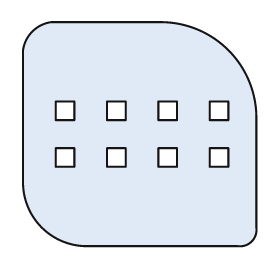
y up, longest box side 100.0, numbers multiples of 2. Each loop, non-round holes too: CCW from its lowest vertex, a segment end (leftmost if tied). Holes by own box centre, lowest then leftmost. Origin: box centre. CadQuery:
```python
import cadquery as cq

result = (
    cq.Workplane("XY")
    .moveTo(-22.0, -48.0)
    .lineTo(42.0, -48.0)
    .threePointArc((48.0, -46.0), (50.0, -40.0))
    .lineTo(50.0, 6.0)
    .threePointArc((38.0, 36.0), (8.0, 48.0))
    .lineTo(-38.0, 48.0)
    .threePointArc((-46.0, 44.0), (-50.0, 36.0))
    .lineTo(-50.0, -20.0)
    .threePointArc((-42.0, -40.0), (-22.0, -48.0))
    .close()
    .moveTo(-36.0, -14.0)
    .lineTo(-28.0, -14.0)
    .lineTo(-28.0, -6.0)
    .lineTo(-36.0, -6.0)
    .close()
    .moveTo(-14.0, -14.0)
    .lineTo(-6.0, -14.0)
    .lineTo(-6.0, -6.0)
    .lineTo(-14.0, -6.0)
    .close()
    .moveTo(8.0, -14.0)
    .lineTo(16.0, -14.0)
    .lineTo(16.0, -6.0)
    .lineTo(8.0, -6.0)
    .close()
    .moveTo(30.0, -14.0)
    .lineTo(38.0, -14.0)
    .lineTo(38.0, -6.0)
    .lineTo(30.0, -6.0)
    .close()
    .moveTo(-36.0, 6.0)
    .lineTo(-28.0, 6.0)
    .lineTo(-28.0, 14.0)
    .lineTo(-36.0, 14.0)
    .close()
    .moveTo(-14.0, 6.0)
    .lineTo(-6.0, 6.0)
    .lineTo(-6.0, 14.0)
    .lineTo(-14.0, 14.0)
    .close()
    .moveTo(8.0, 6.0)
    .lineTo(16.0, 6.0)
    .lineTo(16.0, 14.0)
    .lineTo(8.0, 14.0)
    .close()
    .moveTo(30.0, 6.0)
    .lineTo(38.0, 6.0)
    .lineTo(38.0, 14.0)
    .lineTo(30.0, 14.0)
    .close()
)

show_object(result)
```